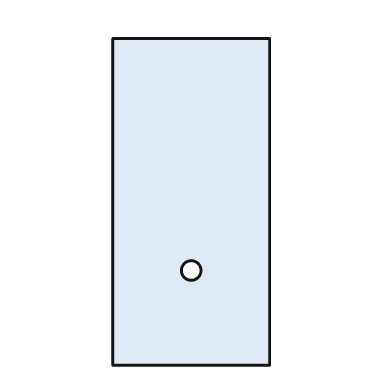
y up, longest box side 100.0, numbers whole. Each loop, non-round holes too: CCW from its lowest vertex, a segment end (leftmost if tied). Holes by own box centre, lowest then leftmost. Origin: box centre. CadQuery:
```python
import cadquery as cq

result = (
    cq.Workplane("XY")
    .moveTo(-24.0, -50.0)
    .lineTo(24.0, -50.0)
    .lineTo(24.0, 50.0)
    .lineTo(-24.0, 50.0)
    .close()
    .moveTo(0.0, -21.0)
    .circle(3.0)
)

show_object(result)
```